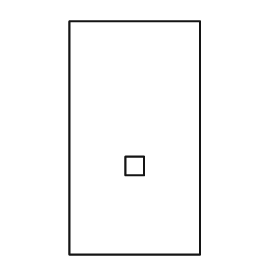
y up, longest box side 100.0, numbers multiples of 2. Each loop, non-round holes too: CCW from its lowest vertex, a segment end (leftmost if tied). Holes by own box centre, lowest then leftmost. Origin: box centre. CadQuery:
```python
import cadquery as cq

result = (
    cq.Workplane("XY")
    .moveTo(-28.0, -50.0)
    .lineTo(28.0, -50.0)
    .lineTo(28.0, 50.0)
    .lineTo(-28.0, 50.0)
    .close()
    .moveTo(-4.0, -16.0)
    .lineTo(4.0, -16.0)
    .lineTo(4.0, -8.0)
    .lineTo(-4.0, -8.0)
    .close()
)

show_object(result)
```